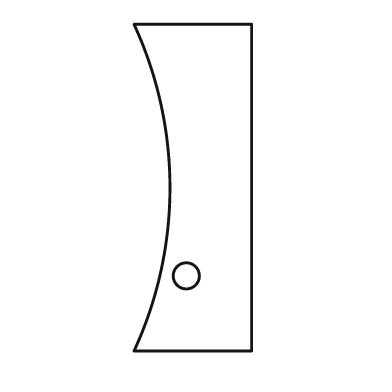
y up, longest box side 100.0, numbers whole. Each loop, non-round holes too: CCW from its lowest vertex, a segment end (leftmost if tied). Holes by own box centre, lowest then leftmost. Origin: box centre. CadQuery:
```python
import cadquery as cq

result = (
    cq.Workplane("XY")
    .moveTo(-18.0, -50.0)
    .lineTo(18.0, -50.0)
    .lineTo(18.0, 50.0)
    .lineTo(-18.0, 50.0)
    .threePointArc((-7.0, 0.0), (-18.0, -50.0))
    .close()
    .moveTo(-2.0, -27.0)
    .circle(4.0)
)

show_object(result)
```